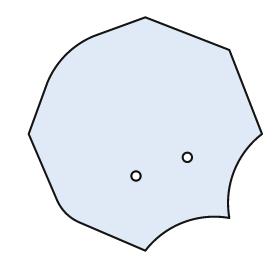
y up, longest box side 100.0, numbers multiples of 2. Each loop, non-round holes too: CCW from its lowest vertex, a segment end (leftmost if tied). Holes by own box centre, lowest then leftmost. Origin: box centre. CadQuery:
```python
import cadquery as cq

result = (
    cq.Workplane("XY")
    .moveTo(0.0, -50.0)
    .threePointArc((16.0, -38.0), (36.0, -36.0))
    .threePointArc((38.0, -16.0), (50.0, 0.0))
    .lineTo(36.0, 36.0)
    .lineTo(0.0, 50.0)
    .lineTo(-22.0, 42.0)
    .threePointArc((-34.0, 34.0), (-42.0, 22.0))
    .lineTo(-50.0, 0.0)
    .lineTo(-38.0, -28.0)
    .threePointArc((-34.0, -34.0), (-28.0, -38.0))
    .close()
    .moveTo(-4.0, -18.0)
    .circle(2.0)
    .moveTo(18.0, -10.0)
    .circle(2.0)
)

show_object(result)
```